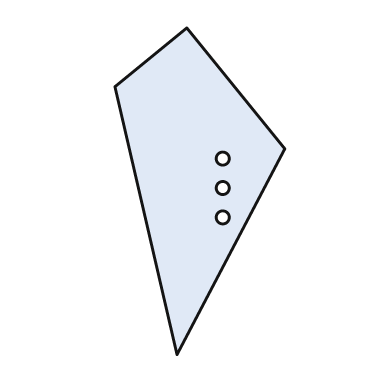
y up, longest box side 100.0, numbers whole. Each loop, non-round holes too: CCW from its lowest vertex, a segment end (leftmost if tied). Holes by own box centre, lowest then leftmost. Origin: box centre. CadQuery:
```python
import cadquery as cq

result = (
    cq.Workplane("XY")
    .moveTo(-7.0, -50.0)
    .lineTo(26.0, 13.0)
    .lineTo(-4.0, 50.0)
    .lineTo(-26.0, 32.0)
    .close()
    .moveTo(7.0, -8.0)
    .circle(2.0)
    .moveTo(7.0, 1.0)
    .circle(2.0)
    .moveTo(7.0, 10.0)
    .circle(2.0)
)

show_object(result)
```